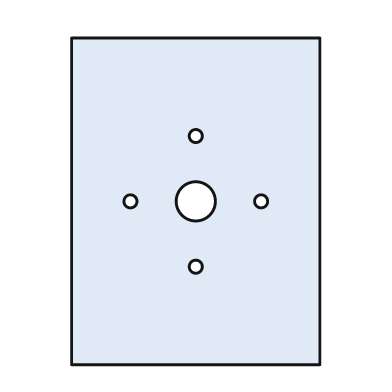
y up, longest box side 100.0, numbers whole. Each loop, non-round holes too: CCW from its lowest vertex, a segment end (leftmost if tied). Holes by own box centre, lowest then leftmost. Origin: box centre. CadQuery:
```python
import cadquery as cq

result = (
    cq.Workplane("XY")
    .moveTo(-38.0, -50.0)
    .lineTo(38.0, -50.0)
    .lineTo(38.0, 50.0)
    .lineTo(-38.0, 50.0)
    .close()
    .moveTo(0.0, -20.0)
    .circle(2.0)
    .moveTo(-20.0, 0.0)
    .circle(2.0)
    .moveTo(0.0, 0.0)
    .circle(6.0)
    .moveTo(20.0, 0.0)
    .circle(2.0)
    .moveTo(0.0, 20.0)
    .circle(2.0)
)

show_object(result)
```